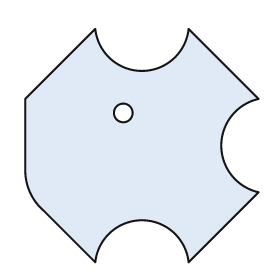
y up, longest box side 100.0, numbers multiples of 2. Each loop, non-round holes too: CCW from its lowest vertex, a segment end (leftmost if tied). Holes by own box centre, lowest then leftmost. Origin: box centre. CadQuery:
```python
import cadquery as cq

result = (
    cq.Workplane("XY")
    .moveTo(-20.0, -50.0)
    .threePointArc((0.0, -32.0), (20.0, -50.0))
    .lineTo(50.0, -20.0)
    .threePointArc((34.0, 0.0), (50.0, 20.0))
    .lineTo(20.0, 50.0)
    .threePointArc((0.0, 32.0), (-20.0, 50.0))
    .lineTo(-50.0, 20.0)
    .lineTo(-50.0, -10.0)
    .threePointArc((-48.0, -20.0), (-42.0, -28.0))
    .close()
    .moveTo(-8.0, 14.0)
    .circle(4.0)
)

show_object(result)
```